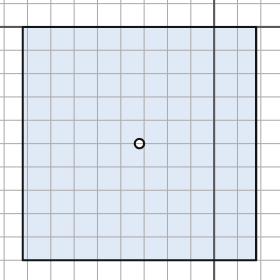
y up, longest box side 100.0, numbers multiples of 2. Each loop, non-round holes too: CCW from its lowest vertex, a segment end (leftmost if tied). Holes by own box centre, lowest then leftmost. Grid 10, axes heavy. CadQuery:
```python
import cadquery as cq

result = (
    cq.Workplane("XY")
    .moveTo(-82.0, -100.0)
    .lineTo(18.0, -100.0)
    .lineTo(18.0, 0.0)
    .lineTo(-82.0, 0.0)
    .close()
    .moveTo(-32.0, -50.0)
    .circle(2.0)
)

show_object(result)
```